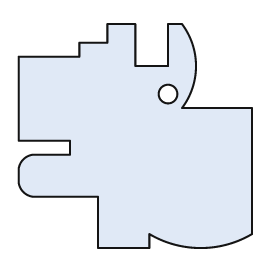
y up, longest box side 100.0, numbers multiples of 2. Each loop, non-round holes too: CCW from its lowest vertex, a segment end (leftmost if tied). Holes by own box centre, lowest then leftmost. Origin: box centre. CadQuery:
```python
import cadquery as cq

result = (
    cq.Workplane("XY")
    .moveTo(-16.0, -48.0)
    .lineTo(6.0, -48.0)
    .lineTo(6.0, -42.0)
    .threePointArc((28.0, -48.0), (50.0, -42.0))
    .lineTo(50.0, 12.0)
    .lineTo(20.0, 12.0)
    .threePointArc((26.0, 30.0), (20.0, 48.0))
    .lineTo(14.0, 48.0)
    .lineTo(14.0, 30.0)
    .lineTo(0.0, 30.0)
    .lineTo(0.0, 48.0)
    .lineTo(-12.0, 48.0)
    .lineTo(-12.0, 40.0)
    .lineTo(-24.0, 40.0)
    .lineTo(-24.0, 34.0)
    .lineTo(-50.0, 34.0)
    .lineTo(-50.0, -2.0)
    .lineTo(-28.0, -2.0)
    .lineTo(-28.0, -8.0)
    .lineTo(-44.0, -8.0)
    .threePointArc((-48.0, -10.0), (-50.0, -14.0))
    .lineTo(-50.0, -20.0)
    .threePointArc((-48.0, -24.0), (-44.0, -26.0))
    .lineTo(-16.0, -26.0)
    .close()
    .moveTo(14.0, 18.0)
    .circle(4.0)
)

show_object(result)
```